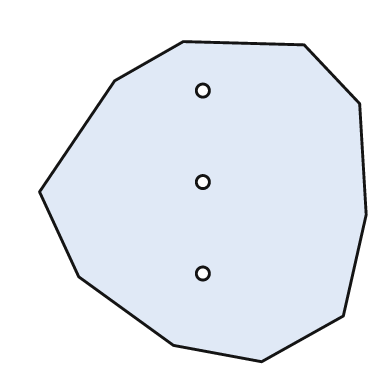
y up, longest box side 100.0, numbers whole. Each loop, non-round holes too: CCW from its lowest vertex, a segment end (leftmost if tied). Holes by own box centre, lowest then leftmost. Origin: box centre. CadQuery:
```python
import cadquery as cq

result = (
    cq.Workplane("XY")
    .moveTo(18.0, -49.0)
    .lineTo(43.0, -35.0)
    .lineTo(50.0, -4.0)
    .lineTo(48.0, 30.0)
    .lineTo(31.0, 48.0)
    .lineTo(-6.0, 49.0)
    .lineTo(-27.0, 37.0)
    .lineTo(-50.0, 3.0)
    .lineTo(-38.0, -23.0)
    .lineTo(-9.0, -44.0)
    .close()
    .moveTo(0.0, -22.0)
    .circle(2.0)
    .moveTo(0.0, 6.0)
    .circle(2.0)
    .moveTo(0.0, 34.0)
    .circle(2.0)
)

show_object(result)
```